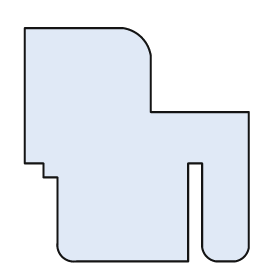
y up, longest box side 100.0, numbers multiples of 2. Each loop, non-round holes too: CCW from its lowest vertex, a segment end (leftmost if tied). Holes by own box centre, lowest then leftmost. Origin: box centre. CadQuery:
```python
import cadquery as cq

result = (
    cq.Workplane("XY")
    .moveTo(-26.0, -50.0)
    .lineTo(22.0, -50.0)
    .lineTo(22.0, -8.0)
    .lineTo(28.0, -8.0)
    .lineTo(28.0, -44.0)
    .threePointArc((30.0, -48.0), (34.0, -50.0))
    .lineTo(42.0, -50.0)
    .threePointArc((46.0, -48.0), (48.0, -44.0))
    .lineTo(48.0, 14.0)
    .lineTo(6.0, 14.0)
    .lineTo(6.0, 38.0)
    .threePointArc((2.0, 46.0), (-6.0, 50.0))
    .lineTo(-48.0, 50.0)
    .lineTo(-48.0, -8.0)
    .lineTo(-40.0, -8.0)
    .lineTo(-40.0, -14.0)
    .lineTo(-34.0, -14.0)
    .lineTo(-34.0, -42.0)
    .threePointArc((-32.0, -48.0), (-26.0, -50.0))
    .close()
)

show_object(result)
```